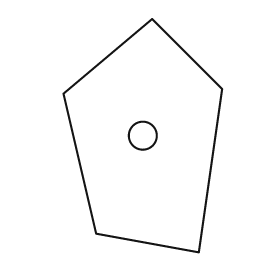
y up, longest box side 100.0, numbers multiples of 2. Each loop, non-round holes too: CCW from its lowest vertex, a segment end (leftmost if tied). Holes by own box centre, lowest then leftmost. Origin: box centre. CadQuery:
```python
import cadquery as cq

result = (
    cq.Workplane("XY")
    .moveTo(24.0, -50.0)
    .lineTo(34.0, 20.0)
    .lineTo(4.0, 50.0)
    .lineTo(-34.0, 18.0)
    .lineTo(-20.0, -42.0)
    .close()
    .moveTo(0.0, 0.0)
    .circle(6.0)
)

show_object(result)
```